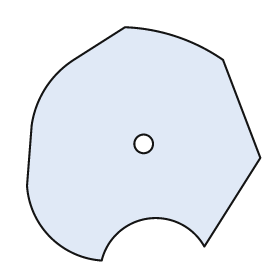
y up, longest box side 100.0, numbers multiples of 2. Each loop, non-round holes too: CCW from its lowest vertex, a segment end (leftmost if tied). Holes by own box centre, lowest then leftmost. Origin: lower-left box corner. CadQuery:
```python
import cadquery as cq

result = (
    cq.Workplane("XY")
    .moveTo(32.0, 0.0)
    .threePointArc((52.0, 18.0), (76.0, 6.0))
    .lineTo(100.0, 44.0)
    .lineTo(84.0, 86.0)
    .threePointArc((64.0, 96.0), (42.0, 100.0))
    .lineTo(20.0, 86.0)
    .threePointArc((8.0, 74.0), (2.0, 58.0))
    .lineTo(0.0, 32.0)
    .threePointArc((10.0, 10.0), (32.0, 0.0))
    .close()
    .moveTo(50.0, 50.0)
    .circle(4.0)
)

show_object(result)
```